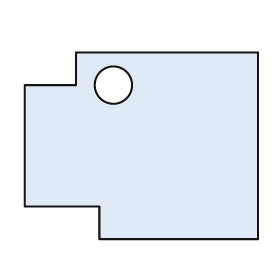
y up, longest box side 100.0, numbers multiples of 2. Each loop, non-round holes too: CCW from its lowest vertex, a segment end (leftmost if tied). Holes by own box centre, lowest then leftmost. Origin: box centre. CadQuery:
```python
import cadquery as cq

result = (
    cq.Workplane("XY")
    .moveTo(-18.0, -40.0)
    .lineTo(50.0, -40.0)
    .lineTo(50.0, 40.0)
    .lineTo(-28.0, 40.0)
    .lineTo(-28.0, 26.0)
    .lineTo(-50.0, 26.0)
    .lineTo(-50.0, -26.0)
    .lineTo(-18.0, -26.0)
    .close()
    .moveTo(-12.0, 26.0)
    .circle(8.0)
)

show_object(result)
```